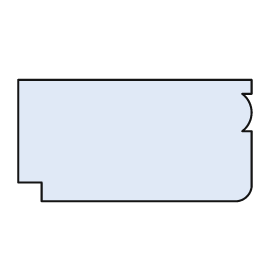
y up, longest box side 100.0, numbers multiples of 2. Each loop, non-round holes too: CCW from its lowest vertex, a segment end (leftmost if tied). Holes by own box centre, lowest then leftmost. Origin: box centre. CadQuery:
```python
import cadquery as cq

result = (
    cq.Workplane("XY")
    .moveTo(-40.0, -26.0)
    .lineTo(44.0, -26.0)
    .threePointArc((48.0, -24.0), (50.0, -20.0))
    .lineTo(50.0, 4.0)
    .lineTo(46.0, 4.0)
    .threePointArc((50.0, 12.0), (46.0, 20.0))
    .lineTo(50.0, 20.0)
    .lineTo(50.0, 26.0)
    .lineTo(-50.0, 26.0)
    .lineTo(-50.0, -18.0)
    .lineTo(-40.0, -18.0)
    .close()
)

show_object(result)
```